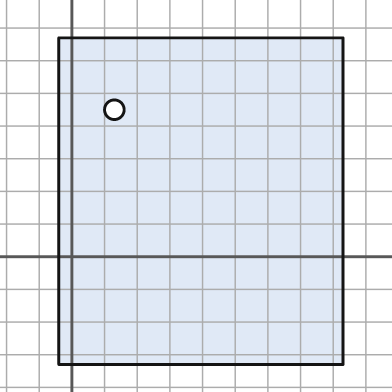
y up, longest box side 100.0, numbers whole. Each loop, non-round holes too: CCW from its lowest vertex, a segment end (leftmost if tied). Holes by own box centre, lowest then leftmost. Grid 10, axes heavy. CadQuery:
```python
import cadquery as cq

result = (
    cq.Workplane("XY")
    .moveTo(-4.0, -33.0)
    .lineTo(83.0, -33.0)
    .lineTo(83.0, 67.0)
    .lineTo(-4.0, 67.0)
    .close()
    .moveTo(13.0, 45.0)
    .circle(3.0)
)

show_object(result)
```